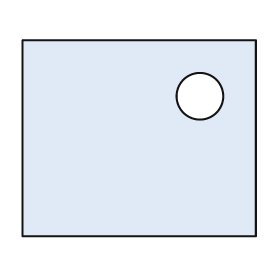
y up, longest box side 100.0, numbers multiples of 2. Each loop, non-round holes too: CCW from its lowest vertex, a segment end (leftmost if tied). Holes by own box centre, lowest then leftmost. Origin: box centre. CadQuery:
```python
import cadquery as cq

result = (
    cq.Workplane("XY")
    .moveTo(-50.0, -42.0)
    .lineTo(50.0, -42.0)
    .lineTo(50.0, 42.0)
    .lineTo(-50.0, 42.0)
    .close()
    .moveTo(26.0, 18.0)
    .circle(10.0)
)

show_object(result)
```